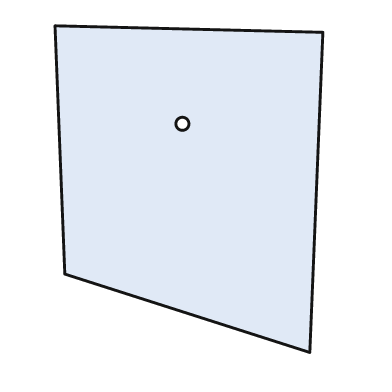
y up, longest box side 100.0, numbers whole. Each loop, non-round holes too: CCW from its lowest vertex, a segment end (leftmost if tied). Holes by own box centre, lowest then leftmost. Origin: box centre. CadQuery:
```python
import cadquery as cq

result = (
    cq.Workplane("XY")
    .moveTo(37.0, -50.0)
    .lineTo(41.0, 48.0)
    .lineTo(-41.0, 50.0)
    .lineTo(-38.0, -26.0)
    .close()
    .moveTo(-2.0, 20.0)
    .circle(2.0)
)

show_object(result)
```